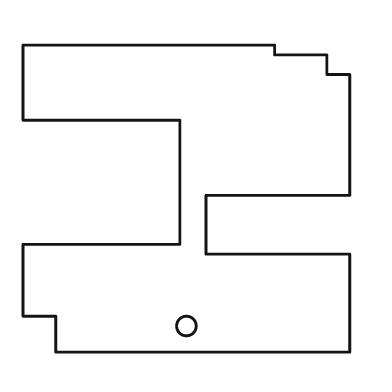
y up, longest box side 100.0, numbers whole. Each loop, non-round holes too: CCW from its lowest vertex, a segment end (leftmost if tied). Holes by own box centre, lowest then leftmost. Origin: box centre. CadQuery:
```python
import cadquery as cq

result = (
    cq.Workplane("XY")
    .moveTo(-40.0, -47.0)
    .lineTo(50.0, -47.0)
    .lineTo(50.0, -17.0)
    .lineTo(6.0, -17.0)
    .lineTo(6.0, 1.0)
    .lineTo(50.0, 1.0)
    .lineTo(50.0, 38.0)
    .lineTo(43.0, 38.0)
    .lineTo(43.0, 44.0)
    .lineTo(27.0, 44.0)
    .lineTo(27.0, 47.0)
    .lineTo(-50.0, 47.0)
    .lineTo(-50.0, 24.0)
    .lineTo(-2.0, 24.0)
    .lineTo(-2.0, -14.0)
    .lineTo(-50.0, -14.0)
    .lineTo(-50.0, -36.0)
    .lineTo(-40.0, -36.0)
    .close()
    .moveTo(0.0, -39.0)
    .circle(3.0)
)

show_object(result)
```